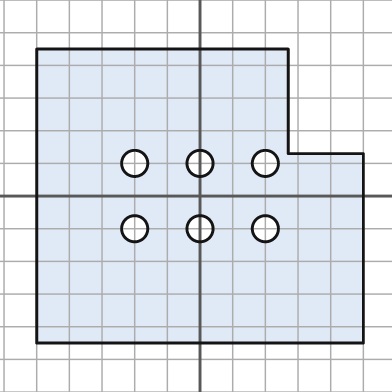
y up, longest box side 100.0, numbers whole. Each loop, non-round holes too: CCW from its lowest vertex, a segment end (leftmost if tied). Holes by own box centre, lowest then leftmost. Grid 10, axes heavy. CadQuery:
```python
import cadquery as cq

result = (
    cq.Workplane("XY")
    .moveTo(-50.0, -45.0)
    .lineTo(50.0, -45.0)
    .lineTo(50.0, 13.0)
    .lineTo(27.0, 13.0)
    .lineTo(27.0, 45.0)
    .lineTo(-50.0, 45.0)
    .close()
    .moveTo(-20.0, -10.0)
    .circle(4.0)
    .moveTo(0.0, -10.0)
    .circle(4.0)
    .moveTo(20.0, -10.0)
    .circle(4.0)
    .moveTo(-20.0, 10.0)
    .circle(4.0)
    .moveTo(0.0, 10.0)
    .circle(4.0)
    .moveTo(20.0, 10.0)
    .circle(4.0)
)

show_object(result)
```